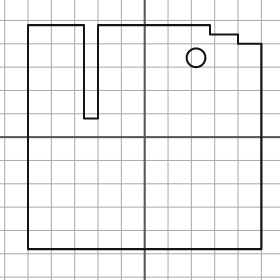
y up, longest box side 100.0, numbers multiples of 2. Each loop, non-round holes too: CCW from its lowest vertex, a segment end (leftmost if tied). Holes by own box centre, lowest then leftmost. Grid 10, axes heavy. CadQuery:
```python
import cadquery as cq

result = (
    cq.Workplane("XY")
    .moveTo(-50.0, -48.0)
    .lineTo(50.0, -48.0)
    .lineTo(50.0, 40.0)
    .lineTo(40.0, 40.0)
    .lineTo(40.0, 44.0)
    .lineTo(28.0, 44.0)
    .lineTo(28.0, 48.0)
    .lineTo(-20.0, 48.0)
    .lineTo(-20.0, 8.0)
    .lineTo(-26.0, 8.0)
    .lineTo(-26.0, 48.0)
    .lineTo(-50.0, 48.0)
    .close()
    .moveTo(22.0, 34.0)
    .circle(4.0)
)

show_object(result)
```